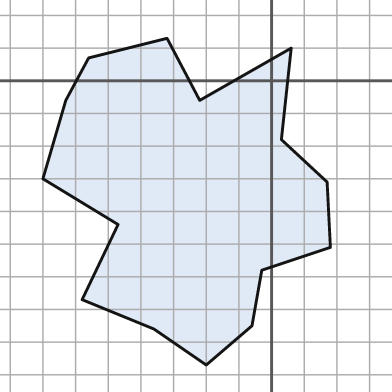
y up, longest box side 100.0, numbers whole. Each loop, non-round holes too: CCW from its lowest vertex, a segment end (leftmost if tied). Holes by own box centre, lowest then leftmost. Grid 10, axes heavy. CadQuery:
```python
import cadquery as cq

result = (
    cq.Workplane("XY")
    .moveTo(-20.0, -87.0)
    .lineTo(-6.0, -75.0)
    .lineTo(-3.0, -58.0)
    .lineTo(18.0, -51.0)
    .lineTo(17.0, -31.0)
    .lineTo(3.0, -18.0)
    .lineTo(6.0, 10.0)
    .lineTo(-22.0, -6.0)
    .lineTo(-32.0, 13.0)
    .lineTo(-56.0, 7.0)
    .lineTo(-63.0, -6.0)
    .lineTo(-70.0, -30.0)
    .lineTo(-47.0, -44.0)
    .lineTo(-58.0, -67.0)
    .lineTo(-36.0, -76.0)
    .close()
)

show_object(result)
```